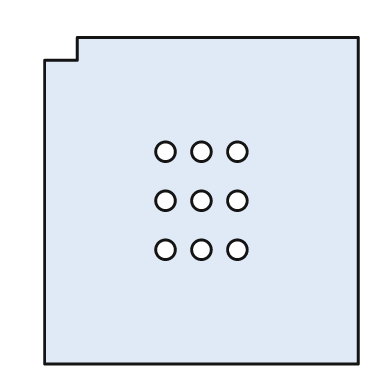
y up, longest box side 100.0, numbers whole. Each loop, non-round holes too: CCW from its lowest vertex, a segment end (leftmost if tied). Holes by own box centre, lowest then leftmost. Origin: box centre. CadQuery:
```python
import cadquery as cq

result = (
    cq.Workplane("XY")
    .moveTo(-48.0, -50.0)
    .lineTo(48.0, -50.0)
    .lineTo(48.0, 50.0)
    .lineTo(-38.0, 50.0)
    .lineTo(-38.0, 43.0)
    .lineTo(-48.0, 43.0)
    .close()
    .moveTo(-11.0, -15.0)
    .circle(3.0)
    .moveTo(0.0, -15.0)
    .circle(3.0)
    .moveTo(11.0, -15.0)
    .circle(3.0)
    .moveTo(-11.0, 0.0)
    .circle(3.0)
    .moveTo(0.0, 0.0)
    .circle(3.0)
    .moveTo(11.0, 0.0)
    .circle(3.0)
    .moveTo(-11.0, 15.0)
    .circle(3.0)
    .moveTo(0.0, 15.0)
    .circle(3.0)
    .moveTo(11.0, 15.0)
    .circle(3.0)
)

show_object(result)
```